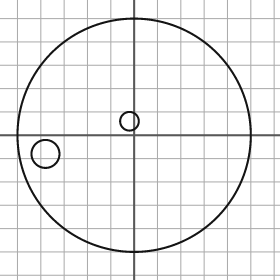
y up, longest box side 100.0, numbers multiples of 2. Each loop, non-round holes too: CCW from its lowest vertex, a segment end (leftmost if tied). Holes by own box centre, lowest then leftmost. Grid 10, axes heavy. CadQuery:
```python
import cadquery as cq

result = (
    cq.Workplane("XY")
    .moveTo(0.0, 0.0)
    .circle(50.0)
    .moveTo(-38.0, -8.0)
    .circle(6.0)
    .moveTo(-2.0, 6.0)
    .circle(4.0)
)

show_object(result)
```